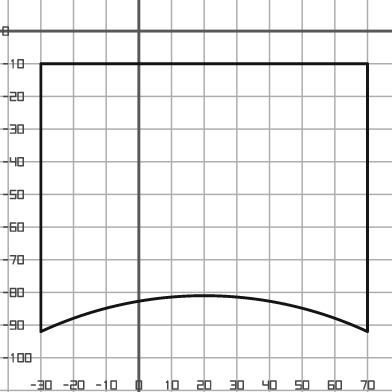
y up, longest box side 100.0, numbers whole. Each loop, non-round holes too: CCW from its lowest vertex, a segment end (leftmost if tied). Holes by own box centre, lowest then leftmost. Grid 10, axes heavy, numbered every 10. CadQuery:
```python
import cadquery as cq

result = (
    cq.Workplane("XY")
    .moveTo(-30.0, -92.0)
    .threePointArc((20.0, -81.0), (70.0, -92.0))
    .lineTo(70.0, -10.0)
    .lineTo(-30.0, -10.0)
    .close()
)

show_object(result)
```